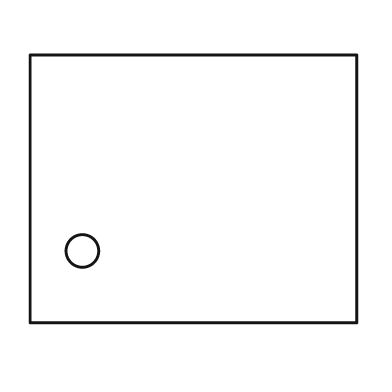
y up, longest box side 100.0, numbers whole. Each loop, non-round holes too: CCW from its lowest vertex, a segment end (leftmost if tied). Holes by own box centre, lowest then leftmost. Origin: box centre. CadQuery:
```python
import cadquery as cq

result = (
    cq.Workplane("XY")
    .moveTo(-50.0, -41.0)
    .lineTo(50.0, -41.0)
    .lineTo(50.0, 41.0)
    .lineTo(-50.0, 41.0)
    .close()
    .moveTo(-34.0, -19.0)
    .circle(5.0)
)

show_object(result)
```